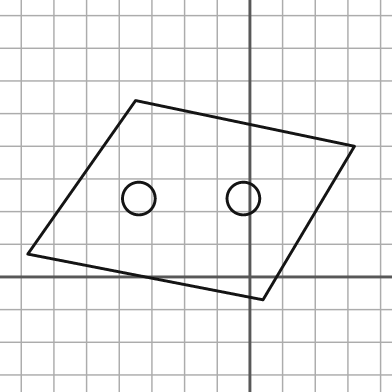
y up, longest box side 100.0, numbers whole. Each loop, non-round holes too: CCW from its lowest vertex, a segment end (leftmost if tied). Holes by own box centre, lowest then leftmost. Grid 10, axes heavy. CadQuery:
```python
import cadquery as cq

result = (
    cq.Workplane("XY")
    .moveTo(4.0, -7.0)
    .lineTo(32.0, 40.0)
    .lineTo(-35.0, 54.0)
    .lineTo(-68.0, 7.0)
    .close()
    .moveTo(-34.0, 24.0)
    .circle(5.0)
    .moveTo(-2.0, 24.0)
    .circle(5.0)
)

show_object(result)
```